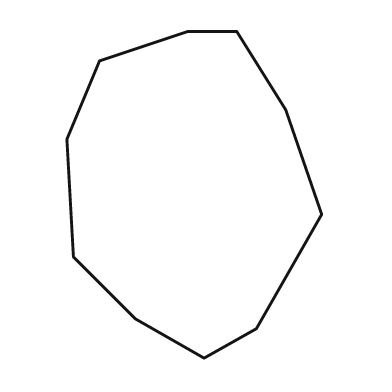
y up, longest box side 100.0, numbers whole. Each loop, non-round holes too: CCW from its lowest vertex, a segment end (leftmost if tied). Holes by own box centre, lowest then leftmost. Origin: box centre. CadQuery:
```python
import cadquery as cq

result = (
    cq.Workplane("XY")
    .moveTo(3.0, -50.0)
    .lineTo(19.0, -41.0)
    .lineTo(39.0, -6.0)
    .lineTo(28.0, 26.0)
    .lineTo(13.0, 50.0)
    .lineTo(-2.0, 50.0)
    .lineTo(-29.0, 41.0)
    .lineTo(-39.0, 17.0)
    .lineTo(-37.0, -19.0)
    .lineTo(-18.0, -38.0)
    .close()
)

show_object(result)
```